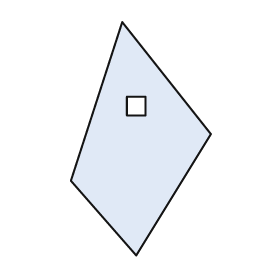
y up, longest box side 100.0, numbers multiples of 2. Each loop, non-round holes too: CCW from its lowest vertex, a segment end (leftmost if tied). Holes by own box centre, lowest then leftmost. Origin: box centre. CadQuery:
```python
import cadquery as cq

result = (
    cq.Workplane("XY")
    .moveTo(-2.0, -50.0)
    .lineTo(30.0, 2.0)
    .lineTo(-8.0, 50.0)
    .lineTo(-30.0, -18.0)
    .close()
    .moveTo(-6.0, 10.0)
    .lineTo(2.0, 10.0)
    .lineTo(2.0, 18.0)
    .lineTo(-6.0, 18.0)
    .close()
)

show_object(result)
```